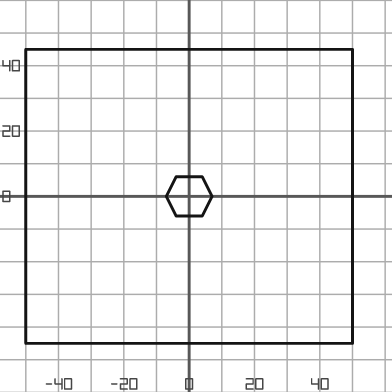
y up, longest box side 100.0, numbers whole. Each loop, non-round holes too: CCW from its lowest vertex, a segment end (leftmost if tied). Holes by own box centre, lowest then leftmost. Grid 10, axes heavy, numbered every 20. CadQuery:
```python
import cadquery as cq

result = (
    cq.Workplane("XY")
    .moveTo(-50.0, -45.0)
    .lineTo(50.0, -45.0)
    .lineTo(50.0, 45.0)
    .lineTo(-50.0, 45.0)
    .close()
    .moveTo(-4.0, -6.0)
    .lineTo(4.0, -6.0)
    .lineTo(7.0, 0.0)
    .lineTo(4.0, 6.0)
    .lineTo(-4.0, 6.0)
    .lineTo(-7.0, 0.0)
    .close()
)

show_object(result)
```